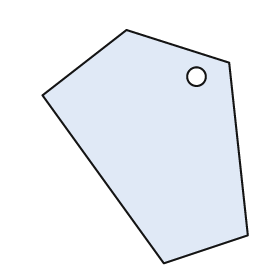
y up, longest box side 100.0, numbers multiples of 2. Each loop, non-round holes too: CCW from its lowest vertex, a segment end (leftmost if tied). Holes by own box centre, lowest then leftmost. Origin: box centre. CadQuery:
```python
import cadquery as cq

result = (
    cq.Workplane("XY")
    .moveTo(8.0, -50.0)
    .lineTo(44.0, -38.0)
    .lineTo(36.0, 36.0)
    .lineTo(-8.0, 50.0)
    .lineTo(-44.0, 22.0)
    .close()
    .moveTo(22.0, 30.0)
    .circle(4.0)
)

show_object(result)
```